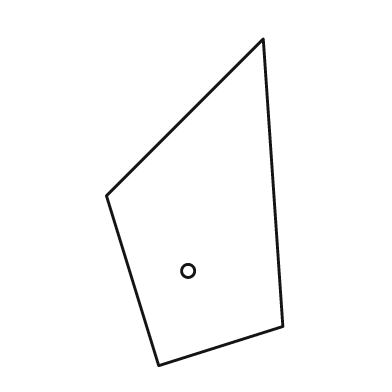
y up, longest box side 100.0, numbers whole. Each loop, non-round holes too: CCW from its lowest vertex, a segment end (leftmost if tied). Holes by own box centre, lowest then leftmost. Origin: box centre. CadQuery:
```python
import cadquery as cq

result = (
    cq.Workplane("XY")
    .moveTo(-11.0, -50.0)
    .lineTo(27.0, -38.0)
    .lineTo(21.0, 50.0)
    .lineTo(-27.0, 2.0)
    .close()
    .moveTo(-2.0, -21.0)
    .circle(2.0)
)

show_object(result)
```